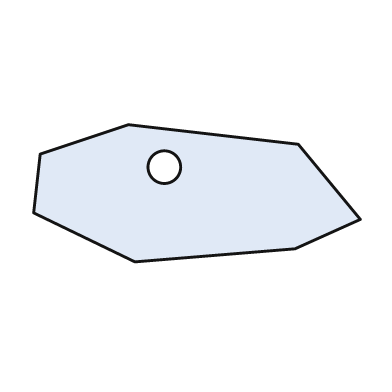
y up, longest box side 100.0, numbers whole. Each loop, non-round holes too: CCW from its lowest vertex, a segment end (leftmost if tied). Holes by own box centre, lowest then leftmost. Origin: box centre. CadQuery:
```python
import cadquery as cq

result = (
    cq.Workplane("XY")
    .moveTo(-19.0, -21.0)
    .lineTo(30.0, -17.0)
    .lineTo(50.0, -8.0)
    .lineTo(31.0, 15.0)
    .lineTo(-21.0, 21.0)
    .lineTo(-48.0, 12.0)
    .lineTo(-50.0, -6.0)
    .close()
    .moveTo(-10.0, 8.0)
    .circle(5.0)
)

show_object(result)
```